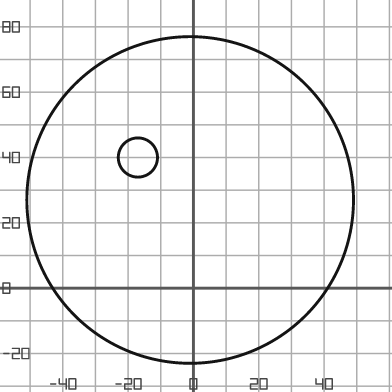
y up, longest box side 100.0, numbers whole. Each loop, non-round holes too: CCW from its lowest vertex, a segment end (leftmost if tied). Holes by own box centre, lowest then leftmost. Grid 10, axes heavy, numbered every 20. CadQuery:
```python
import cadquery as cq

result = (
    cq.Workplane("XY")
    .moveTo(-1.0, 27.0)
    .circle(50.0)
    .moveTo(-17.0, 40.0)
    .circle(6.0)
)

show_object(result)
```